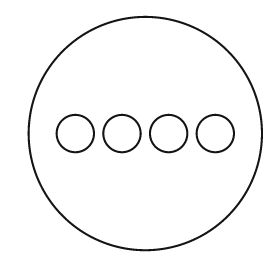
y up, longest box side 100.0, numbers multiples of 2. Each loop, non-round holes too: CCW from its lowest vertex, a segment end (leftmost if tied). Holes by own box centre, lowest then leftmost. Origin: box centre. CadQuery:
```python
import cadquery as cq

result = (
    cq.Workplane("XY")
    .moveTo(0.0, 0.0)
    .circle(50.0)
    .moveTo(-30.0, 0.0)
    .circle(8.0)
    .moveTo(-10.0, 0.0)
    .circle(8.0)
    .moveTo(10.0, 0.0)
    .circle(8.0)
    .moveTo(30.0, 0.0)
    .circle(8.0)
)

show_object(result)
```